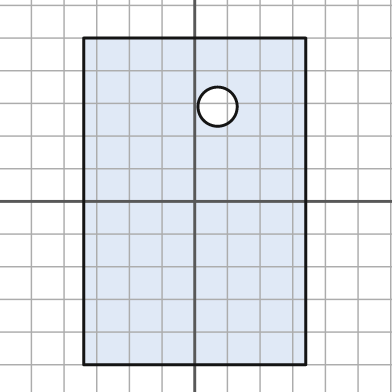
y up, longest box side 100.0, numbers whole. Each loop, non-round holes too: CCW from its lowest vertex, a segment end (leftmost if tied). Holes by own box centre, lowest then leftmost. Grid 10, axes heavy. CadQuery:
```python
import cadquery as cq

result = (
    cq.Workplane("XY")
    .moveTo(-34.0, -50.0)
    .lineTo(34.0, -50.0)
    .lineTo(34.0, 50.0)
    .lineTo(-34.0, 50.0)
    .close()
    .moveTo(7.0, 29.0)
    .circle(6.0)
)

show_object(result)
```